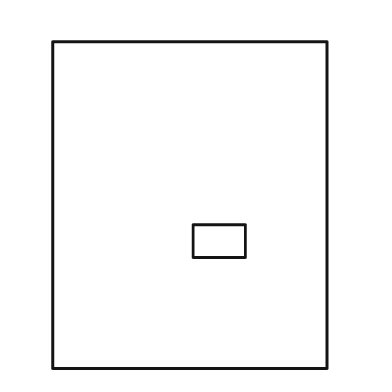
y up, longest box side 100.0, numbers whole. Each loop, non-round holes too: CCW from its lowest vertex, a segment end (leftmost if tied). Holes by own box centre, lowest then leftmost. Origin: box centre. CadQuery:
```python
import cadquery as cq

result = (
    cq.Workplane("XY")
    .moveTo(-42.0, -50.0)
    .lineTo(42.0, -50.0)
    .lineTo(42.0, 50.0)
    .lineTo(-42.0, 50.0)
    .close()
    .moveTo(1.0, -16.0)
    .lineTo(17.0, -16.0)
    .lineTo(17.0, -6.0)
    .lineTo(1.0, -6.0)
    .close()
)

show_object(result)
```